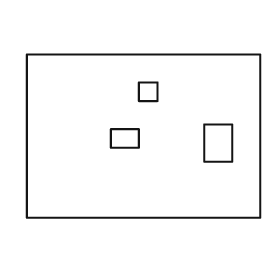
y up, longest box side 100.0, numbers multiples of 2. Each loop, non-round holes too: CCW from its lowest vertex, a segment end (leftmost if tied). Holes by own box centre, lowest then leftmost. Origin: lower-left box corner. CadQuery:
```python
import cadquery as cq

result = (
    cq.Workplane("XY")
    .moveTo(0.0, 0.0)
    .lineTo(100.0, 0.0)
    .lineTo(100.0, 70.0)
    .lineTo(0.0, 70.0)
    .close()
    .moveTo(76.0, 24.0)
    .lineTo(88.0, 24.0)
    .lineTo(88.0, 40.0)
    .lineTo(76.0, 40.0)
    .close()
    .moveTo(36.0, 30.0)
    .lineTo(48.0, 30.0)
    .lineTo(48.0, 38.0)
    .lineTo(36.0, 38.0)
    .close()
    .moveTo(48.0, 50.0)
    .lineTo(56.0, 50.0)
    .lineTo(56.0, 58.0)
    .lineTo(48.0, 58.0)
    .close()
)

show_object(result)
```